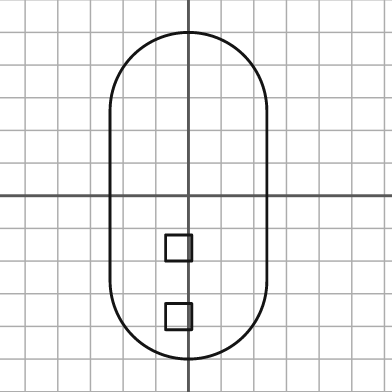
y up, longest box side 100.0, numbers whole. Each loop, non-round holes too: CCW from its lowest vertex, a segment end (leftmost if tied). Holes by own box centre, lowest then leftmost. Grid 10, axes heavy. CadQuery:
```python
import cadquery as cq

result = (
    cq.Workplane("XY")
    .moveTo(-24.0, -26.0)
    .threePointArc((0.0, -50.0), (24.0, -26.0))
    .lineTo(24.0, 26.0)
    .threePointArc((0.0, 50.0), (-24.0, 26.0))
    .close()
    .moveTo(-7.0, -41.0)
    .lineTo(1.0, -41.0)
    .lineTo(1.0, -33.0)
    .lineTo(-7.0, -33.0)
    .close()
    .moveTo(-7.0, -20.0)
    .lineTo(1.0, -20.0)
    .lineTo(1.0, -12.0)
    .lineTo(-7.0, -12.0)
    .close()
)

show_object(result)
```